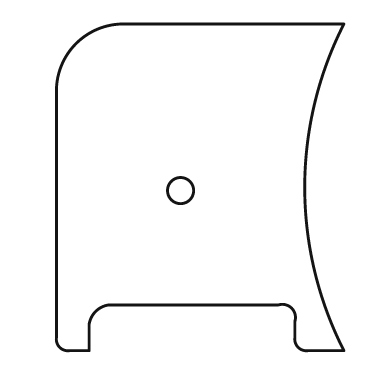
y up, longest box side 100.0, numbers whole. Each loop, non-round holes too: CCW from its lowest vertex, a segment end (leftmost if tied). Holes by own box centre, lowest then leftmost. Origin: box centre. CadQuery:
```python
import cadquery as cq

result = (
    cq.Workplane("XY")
    .moveTo(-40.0, -50.0)
    .lineTo(-34.0, -50.0)
    .lineTo(-34.0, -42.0)
    .threePointArc((-32.0, -38.0), (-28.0, -36.0))
    .lineTo(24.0, -36.0)
    .threePointArc((28.0, -37.0), (29.0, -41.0))
    .lineTo(29.0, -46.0)
    .threePointArc((30.0, -49.0), (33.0, -50.0))
    .lineTo(44.0, -50.0)
    .threePointArc((32.0, 0.0), (44.0, 50.0))
    .lineTo(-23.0, 50.0)
    .threePointArc((-38.0, 44.0), (-44.0, 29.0))
    .lineTo(-44.0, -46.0)
    .threePointArc((-43.0, -49.0), (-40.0, -50.0))
    .close()
    .moveTo(-6.0, -1.0)
    .circle(4.0)
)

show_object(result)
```